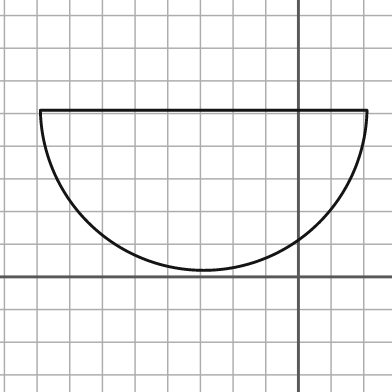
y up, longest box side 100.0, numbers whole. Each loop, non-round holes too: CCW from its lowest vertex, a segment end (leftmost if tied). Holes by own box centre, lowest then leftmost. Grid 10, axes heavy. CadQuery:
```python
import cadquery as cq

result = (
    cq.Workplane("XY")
    .moveTo(-79.0, 51.0)
    .threePointArc((-29.0, 2.0), (21.0, 51.0))
    .close()
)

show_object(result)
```